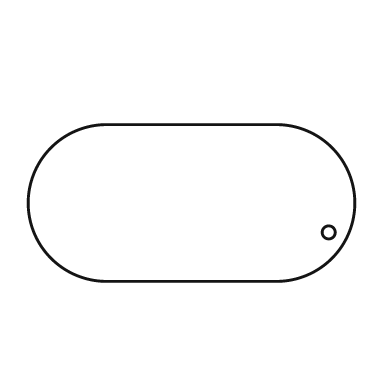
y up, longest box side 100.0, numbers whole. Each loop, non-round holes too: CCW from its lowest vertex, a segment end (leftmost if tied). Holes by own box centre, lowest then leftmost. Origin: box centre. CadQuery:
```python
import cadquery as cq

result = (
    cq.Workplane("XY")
    .moveTo(-26.0, -24.0)
    .lineTo(26.0, -24.0)
    .threePointArc((50.0, 0.0), (26.0, 24.0))
    .lineTo(-26.0, 24.0)
    .threePointArc((-50.0, 0.0), (-26.0, -24.0))
    .close()
    .moveTo(42.0, -9.0)
    .circle(2.0)
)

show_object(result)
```